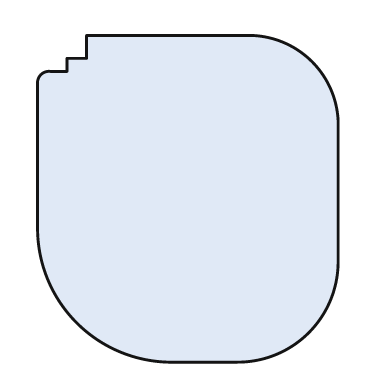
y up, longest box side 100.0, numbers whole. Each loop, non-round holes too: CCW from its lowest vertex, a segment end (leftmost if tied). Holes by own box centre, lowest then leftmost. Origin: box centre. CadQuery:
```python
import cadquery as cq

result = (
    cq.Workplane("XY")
    .moveTo(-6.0, -50.0)
    .lineTo(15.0, -50.0)
    .threePointArc((37.0, -41.0), (46.0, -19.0))
    .lineTo(46.0, 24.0)
    .threePointArc((38.0, 42.0), (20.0, 50.0))
    .lineTo(-31.0, 50.0)
    .lineTo(-31.0, 43.0)
    .lineTo(-37.0, 43.0)
    .lineTo(-37.0, 39.0)
    .lineTo(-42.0, 39.0)
    .threePointArc((-45.0, 38.0), (-46.0, 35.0))
    .lineTo(-46.0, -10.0)
    .threePointArc((-34.0, -38.0), (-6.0, -50.0))
    .close()
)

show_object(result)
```